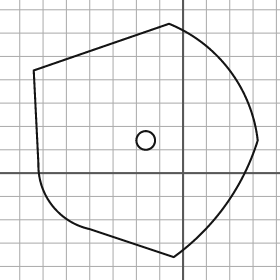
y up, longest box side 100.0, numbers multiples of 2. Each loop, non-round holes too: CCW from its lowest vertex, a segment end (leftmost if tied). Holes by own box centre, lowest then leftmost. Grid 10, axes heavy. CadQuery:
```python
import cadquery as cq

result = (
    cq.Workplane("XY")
    .moveTo(-4.0, -36.0)
    .threePointArc((18.0, -14.0), (32.0, 14.0))
    .threePointArc((20.0, 44.0), (-6.0, 64.0))
    .lineTo(-64.0, 44.0)
    .lineTo(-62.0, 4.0)
    .threePointArc((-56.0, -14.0), (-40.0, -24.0))
    .close()
    .moveTo(-16.0, 14.0)
    .circle(4.0)
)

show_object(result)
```